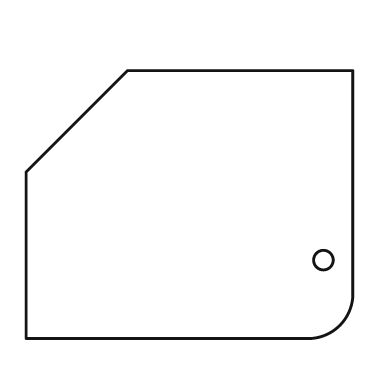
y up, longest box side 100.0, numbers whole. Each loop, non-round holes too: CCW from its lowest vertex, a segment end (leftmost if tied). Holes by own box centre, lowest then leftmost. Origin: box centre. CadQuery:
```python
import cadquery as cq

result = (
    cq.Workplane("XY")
    .moveTo(-50.0, -41.0)
    .lineTo(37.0, -41.0)
    .threePointArc((46.0, -37.0), (50.0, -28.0))
    .lineTo(50.0, 41.0)
    .lineTo(-19.0, 41.0)
    .lineTo(-50.0, 10.0)
    .close()
    .moveTo(41.0, -17.0)
    .circle(3.0)
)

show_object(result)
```